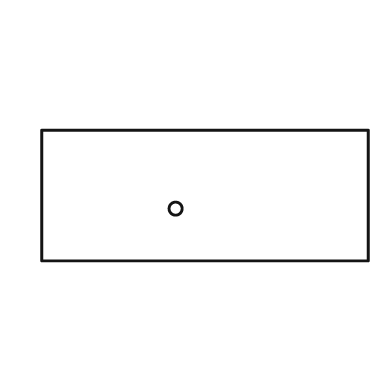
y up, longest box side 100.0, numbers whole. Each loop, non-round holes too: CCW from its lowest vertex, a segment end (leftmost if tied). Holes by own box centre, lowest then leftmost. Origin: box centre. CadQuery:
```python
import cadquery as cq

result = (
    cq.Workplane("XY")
    .moveTo(-50.0, -20.0)
    .lineTo(50.0, -20.0)
    .lineTo(50.0, 20.0)
    .lineTo(-50.0, 20.0)
    .close()
    .moveTo(-9.0, -4.0)
    .circle(2.0)
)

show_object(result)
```